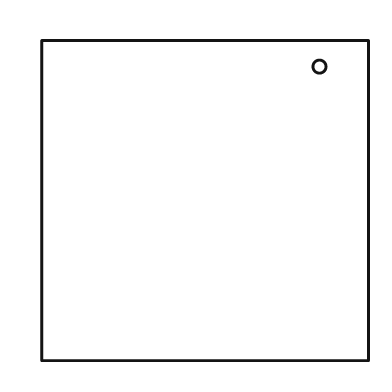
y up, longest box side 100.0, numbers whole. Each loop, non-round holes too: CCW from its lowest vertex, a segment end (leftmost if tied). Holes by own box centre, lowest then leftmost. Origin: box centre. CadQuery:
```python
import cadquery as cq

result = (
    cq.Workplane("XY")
    .moveTo(-50.0, -49.0)
    .lineTo(50.0, -49.0)
    .lineTo(50.0, 49.0)
    .lineTo(-50.0, 49.0)
    .close()
    .moveTo(35.0, 41.0)
    .circle(2.0)
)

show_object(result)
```